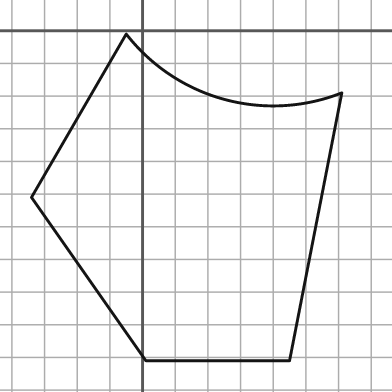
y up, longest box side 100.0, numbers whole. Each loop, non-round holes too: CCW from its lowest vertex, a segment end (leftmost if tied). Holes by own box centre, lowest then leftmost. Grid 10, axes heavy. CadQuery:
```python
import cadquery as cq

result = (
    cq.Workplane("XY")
    .moveTo(1.0, -101.0)
    .lineTo(45.0, -101.0)
    .lineTo(61.0, -19.0)
    .threePointArc((25.0, -21.0), (-5.0, -1.0))
    .lineTo(-34.0, -51.0)
    .close()
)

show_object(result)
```